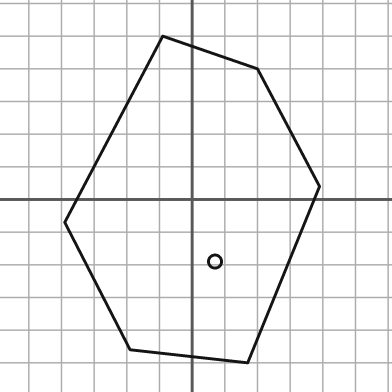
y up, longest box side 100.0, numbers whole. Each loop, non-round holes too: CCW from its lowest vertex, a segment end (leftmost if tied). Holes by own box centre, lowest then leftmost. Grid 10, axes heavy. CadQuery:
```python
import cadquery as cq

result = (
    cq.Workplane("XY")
    .moveTo(17.0, -50.0)
    .lineTo(39.0, 4.0)
    .lineTo(20.0, 40.0)
    .lineTo(-9.0, 50.0)
    .lineTo(-39.0, -7.0)
    .lineTo(-19.0, -46.0)
    .close()
    .moveTo(7.0, -19.0)
    .circle(2.0)
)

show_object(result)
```